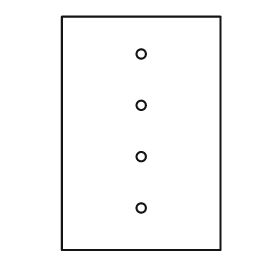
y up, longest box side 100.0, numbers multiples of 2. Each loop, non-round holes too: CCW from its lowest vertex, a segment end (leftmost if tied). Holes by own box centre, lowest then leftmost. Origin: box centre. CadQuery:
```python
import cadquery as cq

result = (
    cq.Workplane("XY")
    .moveTo(-34.0, -50.0)
    .lineTo(34.0, -50.0)
    .lineTo(34.0, 50.0)
    .lineTo(-34.0, 50.0)
    .close()
    .moveTo(0.0, -32.0)
    .circle(2.0)
    .moveTo(0.0, -10.0)
    .circle(2.0)
    .moveTo(0.0, 12.0)
    .circle(2.0)
    .moveTo(0.0, 34.0)
    .circle(2.0)
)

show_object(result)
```